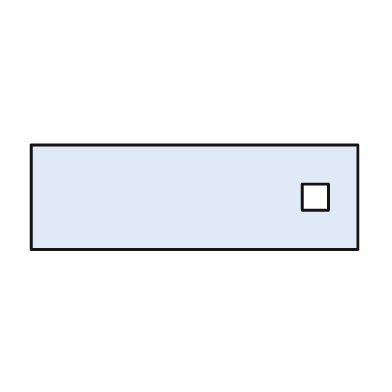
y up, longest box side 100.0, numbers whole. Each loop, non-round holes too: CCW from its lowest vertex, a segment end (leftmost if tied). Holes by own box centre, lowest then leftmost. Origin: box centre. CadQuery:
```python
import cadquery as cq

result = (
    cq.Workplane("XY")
    .moveTo(-50.0, -16.0)
    .lineTo(50.0, -16.0)
    .lineTo(50.0, 16.0)
    .lineTo(-50.0, 16.0)
    .close()
    .moveTo(33.0, -4.0)
    .lineTo(41.0, -4.0)
    .lineTo(41.0, 4.0)
    .lineTo(33.0, 4.0)
    .close()
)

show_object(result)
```